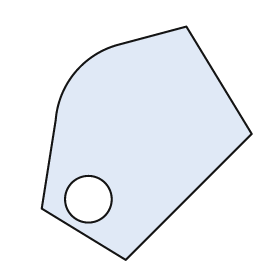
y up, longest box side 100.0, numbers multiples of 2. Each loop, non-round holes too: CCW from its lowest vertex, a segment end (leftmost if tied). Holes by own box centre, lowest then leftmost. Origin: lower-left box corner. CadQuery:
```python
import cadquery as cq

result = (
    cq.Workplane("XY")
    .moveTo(36.0, 0.0)
    .lineTo(90.0, 54.0)
    .lineTo(62.0, 100.0)
    .lineTo(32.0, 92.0)
    .threePointArc((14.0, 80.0), (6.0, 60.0))
    .lineTo(0.0, 22.0)
    .close()
    .moveTo(20.0, 26.0)
    .circle(10.0)
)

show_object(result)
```